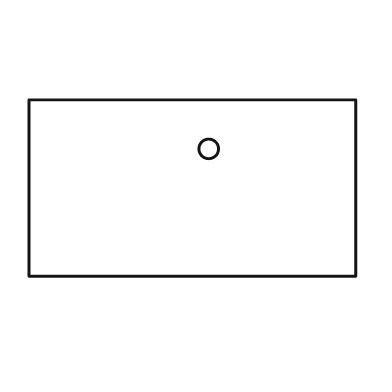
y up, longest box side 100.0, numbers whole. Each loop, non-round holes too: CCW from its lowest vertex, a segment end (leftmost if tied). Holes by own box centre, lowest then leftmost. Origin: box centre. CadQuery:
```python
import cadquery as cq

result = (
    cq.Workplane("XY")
    .moveTo(-50.0, -27.0)
    .lineTo(50.0, -27.0)
    .lineTo(50.0, 27.0)
    .lineTo(-50.0, 27.0)
    .close()
    .moveTo(5.0, 12.0)
    .circle(3.0)
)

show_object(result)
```